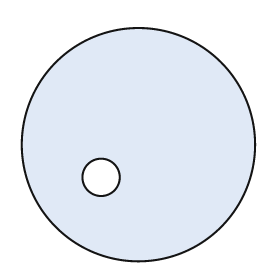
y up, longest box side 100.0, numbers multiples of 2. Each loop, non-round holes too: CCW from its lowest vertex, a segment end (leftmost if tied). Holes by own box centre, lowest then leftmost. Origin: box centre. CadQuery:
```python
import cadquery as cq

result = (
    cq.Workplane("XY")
    .moveTo(0.0, 0.0)
    .circle(50.0)
    .moveTo(-16.0, -14.0)
    .circle(8.0)
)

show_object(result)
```